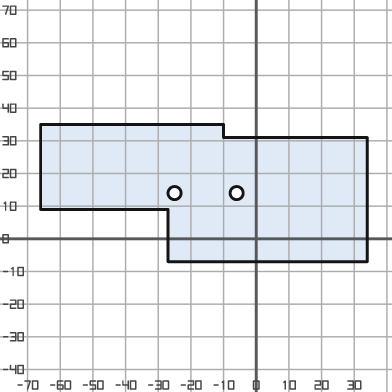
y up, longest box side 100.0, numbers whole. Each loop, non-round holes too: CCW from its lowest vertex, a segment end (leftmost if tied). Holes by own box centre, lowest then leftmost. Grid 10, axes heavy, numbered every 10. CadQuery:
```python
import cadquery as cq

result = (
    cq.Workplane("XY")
    .moveTo(-27.0, -7.0)
    .lineTo(34.0, -7.0)
    .lineTo(34.0, 31.0)
    .lineTo(-10.0, 31.0)
    .lineTo(-10.0, 35.0)
    .lineTo(-66.0, 35.0)
    .lineTo(-66.0, 9.0)
    .lineTo(-27.0, 9.0)
    .close()
    .moveTo(-25.0, 14.0)
    .circle(2.0)
    .moveTo(-6.0, 14.0)
    .circle(2.0)
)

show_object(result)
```